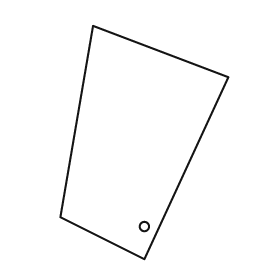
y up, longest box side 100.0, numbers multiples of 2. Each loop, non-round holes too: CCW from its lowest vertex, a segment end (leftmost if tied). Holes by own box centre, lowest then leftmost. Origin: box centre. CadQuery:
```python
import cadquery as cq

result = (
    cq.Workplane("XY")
    .moveTo(0.0, -50.0)
    .lineTo(36.0, 28.0)
    .lineTo(-22.0, 50.0)
    .lineTo(-36.0, -32.0)
    .close()
    .moveTo(0.0, -36.0)
    .circle(2.0)
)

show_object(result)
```